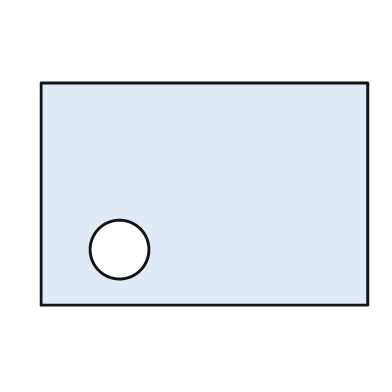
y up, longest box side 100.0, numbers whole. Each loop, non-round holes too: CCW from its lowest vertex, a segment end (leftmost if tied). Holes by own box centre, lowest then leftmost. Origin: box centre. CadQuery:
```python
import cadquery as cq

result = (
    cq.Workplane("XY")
    .moveTo(-50.0, -34.0)
    .lineTo(50.0, -34.0)
    .lineTo(50.0, 34.0)
    .lineTo(-50.0, 34.0)
    .close()
    .moveTo(-26.0, -17.0)
    .circle(9.0)
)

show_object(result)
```